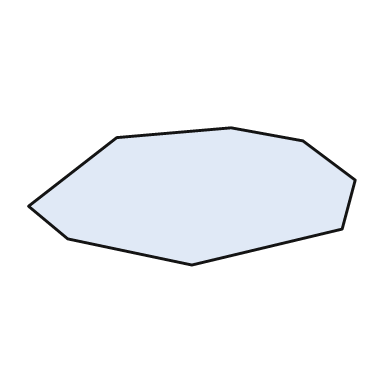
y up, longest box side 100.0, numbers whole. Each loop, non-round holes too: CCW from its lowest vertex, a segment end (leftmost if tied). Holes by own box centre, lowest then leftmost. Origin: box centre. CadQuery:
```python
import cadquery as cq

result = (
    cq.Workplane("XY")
    .moveTo(0.0, -21.0)
    .lineTo(46.0, -10.0)
    .lineTo(50.0, 5.0)
    .lineTo(34.0, 17.0)
    .lineTo(12.0, 21.0)
    .lineTo(-23.0, 18.0)
    .lineTo(-50.0, -3.0)
    .lineTo(-38.0, -13.0)
    .close()
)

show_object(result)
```